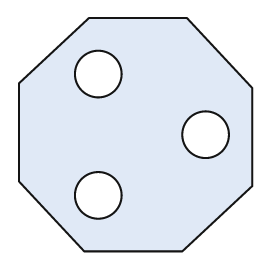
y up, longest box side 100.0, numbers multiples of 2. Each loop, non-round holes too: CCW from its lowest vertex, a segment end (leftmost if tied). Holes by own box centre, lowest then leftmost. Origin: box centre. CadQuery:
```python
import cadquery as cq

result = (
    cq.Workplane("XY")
    .moveTo(-22.0, -50.0)
    .lineTo(20.0, -50.0)
    .lineTo(50.0, -22.0)
    .lineTo(50.0, 20.0)
    .lineTo(22.0, 50.0)
    .lineTo(-20.0, 50.0)
    .lineTo(-50.0, 22.0)
    .lineTo(-50.0, -20.0)
    .close()
    .moveTo(-16.0, -26.0)
    .circle(10.0)
    .moveTo(30.0, 0.0)
    .circle(10.0)
    .moveTo(-16.0, 26.0)
    .circle(10.0)
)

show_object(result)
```